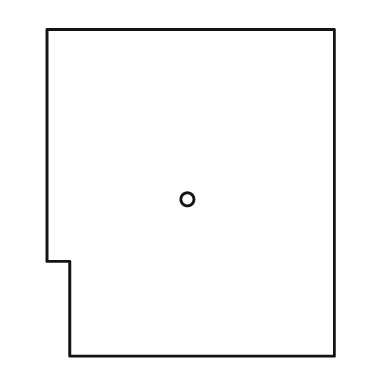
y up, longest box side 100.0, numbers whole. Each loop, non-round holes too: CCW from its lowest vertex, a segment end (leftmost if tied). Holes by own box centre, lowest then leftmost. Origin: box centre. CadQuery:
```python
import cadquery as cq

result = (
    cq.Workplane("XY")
    .moveTo(-37.0, -50.0)
    .lineTo(44.0, -50.0)
    .lineTo(44.0, 50.0)
    .lineTo(-44.0, 50.0)
    .lineTo(-44.0, -21.0)
    .lineTo(-37.0, -21.0)
    .close()
    .moveTo(-1.0, -2.0)
    .circle(2.0)
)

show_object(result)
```